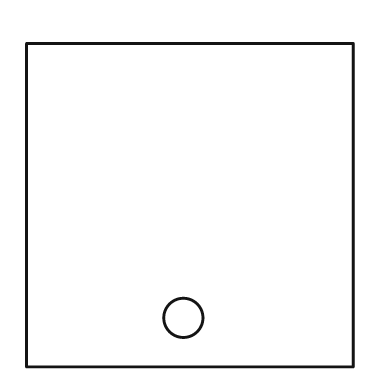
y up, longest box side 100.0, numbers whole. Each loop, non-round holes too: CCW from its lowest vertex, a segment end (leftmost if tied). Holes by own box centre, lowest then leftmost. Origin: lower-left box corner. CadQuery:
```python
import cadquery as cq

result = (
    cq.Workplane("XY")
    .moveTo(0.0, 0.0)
    .lineTo(100.0, 0.0)
    .lineTo(100.0, 99.0)
    .lineTo(0.0, 99.0)
    .close()
    .moveTo(48.0, 15.0)
    .circle(6.0)
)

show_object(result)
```